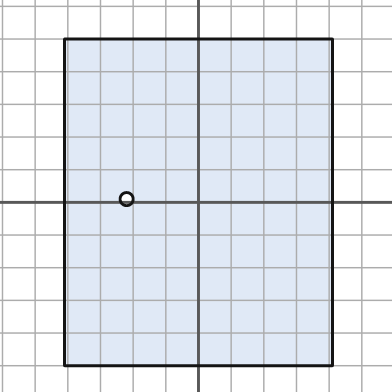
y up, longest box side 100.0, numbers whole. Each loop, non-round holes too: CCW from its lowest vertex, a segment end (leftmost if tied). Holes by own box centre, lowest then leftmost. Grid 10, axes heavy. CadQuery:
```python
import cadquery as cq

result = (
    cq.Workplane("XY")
    .moveTo(-41.0, -50.0)
    .lineTo(41.0, -50.0)
    .lineTo(41.0, 50.0)
    .lineTo(-41.0, 50.0)
    .close()
    .moveTo(-22.0, 1.0)
    .circle(2.0)
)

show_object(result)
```